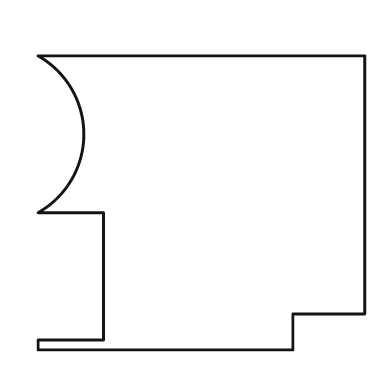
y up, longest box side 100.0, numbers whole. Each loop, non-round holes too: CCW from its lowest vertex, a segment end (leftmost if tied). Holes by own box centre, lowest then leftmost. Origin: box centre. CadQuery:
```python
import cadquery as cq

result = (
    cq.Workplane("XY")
    .moveTo(-50.0, -45.0)
    .lineTo(28.0, -45.0)
    .lineTo(28.0, -34.0)
    .lineTo(50.0, -34.0)
    .lineTo(50.0, 45.0)
    .lineTo(-50.0, 45.0)
    .threePointArc((-36.0, 21.0), (-50.0, -3.0))
    .lineTo(-30.0, -3.0)
    .lineTo(-30.0, -42.0)
    .lineTo(-50.0, -42.0)
    .close()
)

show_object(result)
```